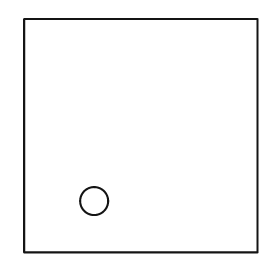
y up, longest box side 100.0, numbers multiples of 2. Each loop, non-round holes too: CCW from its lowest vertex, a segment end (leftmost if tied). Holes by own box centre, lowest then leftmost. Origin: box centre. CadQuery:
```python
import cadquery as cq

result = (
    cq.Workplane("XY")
    .moveTo(-50.0, -50.0)
    .lineTo(50.0, -50.0)
    .lineTo(50.0, 50.0)
    .lineTo(-50.0, 50.0)
    .close()
    .moveTo(-20.0, -28.0)
    .circle(6.0)
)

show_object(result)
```